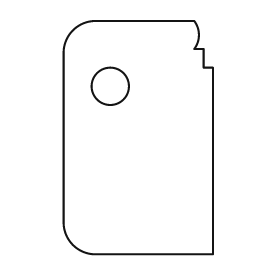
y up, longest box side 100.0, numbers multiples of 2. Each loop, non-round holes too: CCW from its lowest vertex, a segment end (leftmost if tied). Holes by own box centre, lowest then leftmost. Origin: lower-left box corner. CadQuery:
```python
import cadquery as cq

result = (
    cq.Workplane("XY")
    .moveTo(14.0, 0.0)
    .lineTo(64.0, 0.0)
    .lineTo(64.0, 80.0)
    .lineTo(60.0, 80.0)
    .lineTo(60.0, 88.0)
    .lineTo(56.0, 88.0)
    .threePointArc((58.0, 94.0), (56.0, 100.0))
    .lineTo(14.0, 100.0)
    .threePointArc((4.0, 96.0), (0.0, 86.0))
    .lineTo(0.0, 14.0)
    .threePointArc((4.0, 4.0), (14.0, 0.0))
    .close()
    .moveTo(20.0, 72.0)
    .circle(8.0)
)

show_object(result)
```